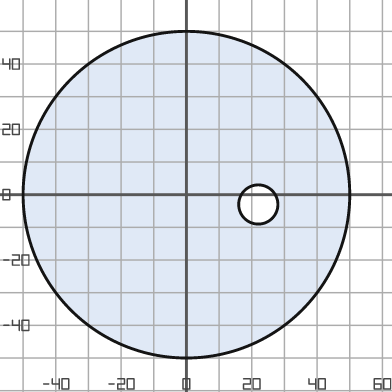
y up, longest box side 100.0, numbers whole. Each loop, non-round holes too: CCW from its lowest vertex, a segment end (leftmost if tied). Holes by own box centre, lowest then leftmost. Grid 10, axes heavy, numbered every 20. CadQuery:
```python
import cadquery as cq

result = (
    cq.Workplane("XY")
    .moveTo(0.0, 0.0)
    .circle(50.0)
    .moveTo(22.0, -3.0)
    .circle(6.0)
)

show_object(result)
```